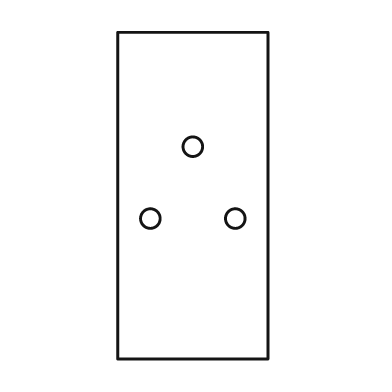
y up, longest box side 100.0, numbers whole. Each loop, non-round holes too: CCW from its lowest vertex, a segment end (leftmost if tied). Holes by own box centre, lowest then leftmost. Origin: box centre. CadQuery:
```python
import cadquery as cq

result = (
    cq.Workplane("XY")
    .moveTo(-23.0, -50.0)
    .lineTo(23.0, -50.0)
    .lineTo(23.0, 50.0)
    .lineTo(-23.0, 50.0)
    .close()
    .moveTo(-13.0, -7.0)
    .circle(3.0)
    .moveTo(13.0, -7.0)
    .circle(3.0)
    .moveTo(0.0, 15.0)
    .circle(3.0)
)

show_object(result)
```